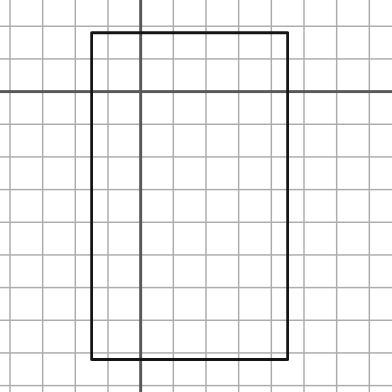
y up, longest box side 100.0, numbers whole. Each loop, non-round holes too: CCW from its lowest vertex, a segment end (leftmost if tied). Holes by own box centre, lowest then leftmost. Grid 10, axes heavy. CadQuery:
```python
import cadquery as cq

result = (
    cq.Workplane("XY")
    .moveTo(-15.0, -82.0)
    .lineTo(45.0, -82.0)
    .lineTo(45.0, 18.0)
    .lineTo(-15.0, 18.0)
    .close()
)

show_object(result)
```